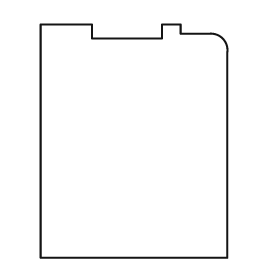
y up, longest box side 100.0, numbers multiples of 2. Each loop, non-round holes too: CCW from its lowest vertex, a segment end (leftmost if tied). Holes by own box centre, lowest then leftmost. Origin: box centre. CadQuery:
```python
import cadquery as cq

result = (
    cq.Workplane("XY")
    .moveTo(-40.0, -50.0)
    .lineTo(40.0, -50.0)
    .lineTo(40.0, 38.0)
    .threePointArc((38.0, 44.0), (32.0, 46.0))
    .lineTo(20.0, 46.0)
    .lineTo(20.0, 50.0)
    .lineTo(12.0, 50.0)
    .lineTo(12.0, 44.0)
    .lineTo(-18.0, 44.0)
    .lineTo(-18.0, 50.0)
    .lineTo(-40.0, 50.0)
    .close()
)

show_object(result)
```